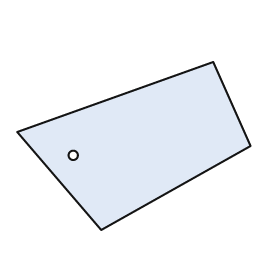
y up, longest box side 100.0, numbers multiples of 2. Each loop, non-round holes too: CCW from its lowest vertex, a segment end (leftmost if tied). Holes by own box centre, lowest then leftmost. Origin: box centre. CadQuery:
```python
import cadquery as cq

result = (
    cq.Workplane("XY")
    .moveTo(-14.0, -36.0)
    .lineTo(50.0, 0.0)
    .lineTo(34.0, 36.0)
    .lineTo(-50.0, 6.0)
    .close()
    .moveTo(-26.0, -4.0)
    .circle(2.0)
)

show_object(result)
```